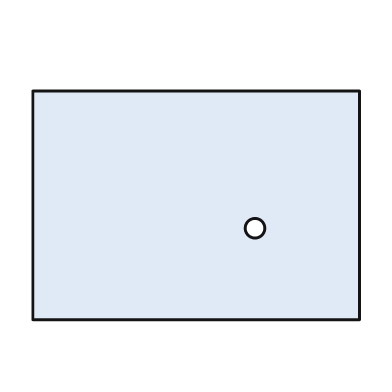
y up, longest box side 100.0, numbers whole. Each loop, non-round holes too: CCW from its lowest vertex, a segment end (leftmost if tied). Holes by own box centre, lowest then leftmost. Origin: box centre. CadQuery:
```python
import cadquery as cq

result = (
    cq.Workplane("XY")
    .moveTo(-50.0, -35.0)
    .lineTo(50.0, -35.0)
    .lineTo(50.0, 35.0)
    .lineTo(-50.0, 35.0)
    .close()
    .moveTo(18.0, -7.0)
    .circle(3.0)
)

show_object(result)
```